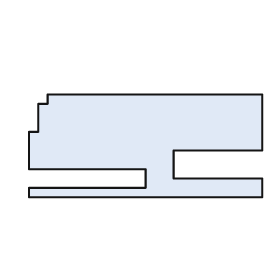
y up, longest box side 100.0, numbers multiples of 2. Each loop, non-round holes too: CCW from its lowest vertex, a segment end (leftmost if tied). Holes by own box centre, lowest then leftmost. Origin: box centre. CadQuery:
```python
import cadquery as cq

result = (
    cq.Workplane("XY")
    .moveTo(-50.0, -22.0)
    .lineTo(50.0, -22.0)
    .lineTo(50.0, -14.0)
    .lineTo(12.0, -14.0)
    .lineTo(12.0, -2.0)
    .lineTo(50.0, -2.0)
    .lineTo(50.0, 22.0)
    .lineTo(-42.0, 22.0)
    .lineTo(-42.0, 18.0)
    .lineTo(-46.0, 18.0)
    .lineTo(-46.0, 6.0)
    .lineTo(-50.0, 6.0)
    .lineTo(-50.0, -10.0)
    .lineTo(0.0, -10.0)
    .lineTo(0.0, -18.0)
    .lineTo(-50.0, -18.0)
    .close()
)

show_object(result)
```